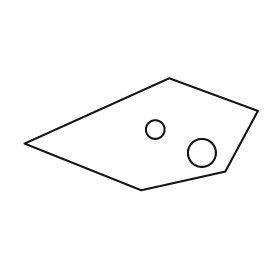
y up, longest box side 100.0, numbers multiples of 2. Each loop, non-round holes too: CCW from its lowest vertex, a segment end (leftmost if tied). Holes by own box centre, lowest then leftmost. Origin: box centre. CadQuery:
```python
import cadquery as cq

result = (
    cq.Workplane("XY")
    .moveTo(0.0, -24.0)
    .lineTo(36.0, -16.0)
    .lineTo(50.0, 10.0)
    .lineTo(12.0, 24.0)
    .lineTo(-50.0, -4.0)
    .close()
    .moveTo(26.0, -8.0)
    .circle(6.0)
    .moveTo(6.0, 2.0)
    .circle(4.0)
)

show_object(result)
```